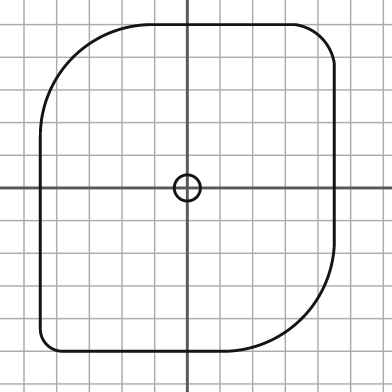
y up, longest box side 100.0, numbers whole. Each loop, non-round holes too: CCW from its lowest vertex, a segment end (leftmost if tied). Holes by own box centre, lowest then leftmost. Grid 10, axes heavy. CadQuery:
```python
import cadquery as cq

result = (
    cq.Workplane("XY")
    .moveTo(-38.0, -50.0)
    .lineTo(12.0, -50.0)
    .threePointArc((35.0, -40.0), (45.0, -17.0))
    .lineTo(45.0, 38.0)
    .threePointArc((41.0, 46.0), (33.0, 50.0))
    .lineTo(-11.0, 50.0)
    .threePointArc((-35.0, 40.0), (-45.0, 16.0))
    .lineTo(-45.0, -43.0)
    .threePointArc((-43.0, -48.0), (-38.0, -50.0))
    .close()
    .moveTo(0.0, 0.0)
    .circle(4.0)
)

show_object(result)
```